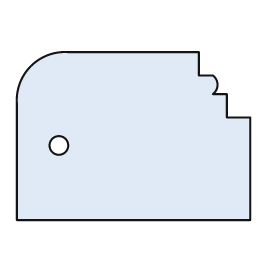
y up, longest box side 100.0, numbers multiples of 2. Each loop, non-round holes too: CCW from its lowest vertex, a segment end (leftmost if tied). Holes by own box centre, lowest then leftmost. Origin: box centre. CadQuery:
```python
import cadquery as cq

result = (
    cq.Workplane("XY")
    .moveTo(-50.0, -36.0)
    .lineTo(50.0, -36.0)
    .lineTo(50.0, 8.0)
    .lineTo(40.0, 8.0)
    .lineTo(40.0, 18.0)
    .lineTo(34.0, 18.0)
    .threePointArc((36.0, 22.0), (34.0, 26.0))
    .lineTo(28.0, 26.0)
    .lineTo(28.0, 36.0)
    .lineTo(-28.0, 36.0)
    .threePointArc((-44.0, 30.0), (-50.0, 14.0))
    .close()
    .moveTo(-32.0, -4.0)
    .circle(4.0)
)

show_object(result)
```